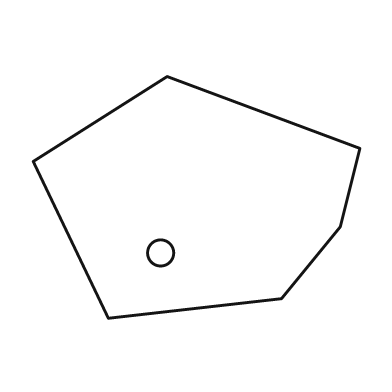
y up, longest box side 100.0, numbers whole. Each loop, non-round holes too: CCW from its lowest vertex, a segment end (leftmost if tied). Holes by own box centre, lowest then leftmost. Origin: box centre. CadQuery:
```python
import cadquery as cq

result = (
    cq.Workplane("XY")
    .moveTo(-27.0, -37.0)
    .lineTo(26.0, -31.0)
    .lineTo(44.0, -9.0)
    .lineTo(50.0, 15.0)
    .lineTo(-9.0, 37.0)
    .lineTo(-50.0, 11.0)
    .close()
    .moveTo(-11.0, -17.0)
    .circle(4.0)
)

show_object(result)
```